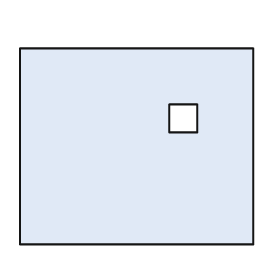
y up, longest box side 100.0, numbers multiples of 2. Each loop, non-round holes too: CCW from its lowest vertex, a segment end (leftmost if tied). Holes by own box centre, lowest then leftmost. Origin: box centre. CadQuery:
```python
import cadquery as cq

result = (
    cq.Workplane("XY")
    .moveTo(-50.0, -42.0)
    .lineTo(50.0, -42.0)
    .lineTo(50.0, 42.0)
    .lineTo(-50.0, 42.0)
    .close()
    .moveTo(14.0, 6.0)
    .lineTo(26.0, 6.0)
    .lineTo(26.0, 18.0)
    .lineTo(14.0, 18.0)
    .close()
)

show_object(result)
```